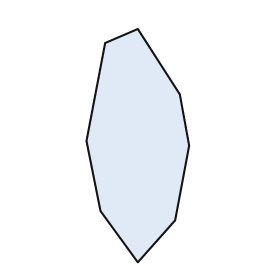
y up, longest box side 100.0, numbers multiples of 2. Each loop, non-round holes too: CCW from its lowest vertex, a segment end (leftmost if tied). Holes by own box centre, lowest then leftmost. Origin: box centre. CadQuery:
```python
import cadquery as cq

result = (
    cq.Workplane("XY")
    .moveTo(0.0, -50.0)
    .lineTo(16.0, -32.0)
    .lineTo(22.0, 0.0)
    .lineTo(18.0, 22.0)
    .lineTo(0.0, 50.0)
    .lineTo(-14.0, 44.0)
    .lineTo(-22.0, 2.0)
    .lineTo(-16.0, -28.0)
    .close()
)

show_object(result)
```